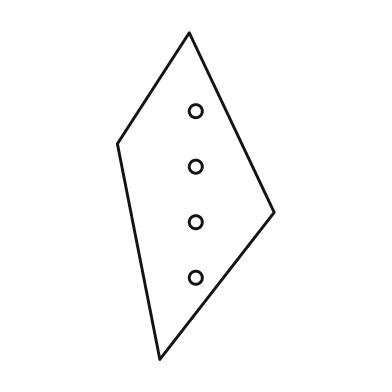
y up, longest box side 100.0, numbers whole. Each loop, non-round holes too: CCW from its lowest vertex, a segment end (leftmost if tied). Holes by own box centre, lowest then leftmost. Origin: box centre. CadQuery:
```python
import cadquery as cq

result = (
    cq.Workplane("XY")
    .moveTo(-11.0, -50.0)
    .lineTo(24.0, -5.0)
    .lineTo(-2.0, 50.0)
    .lineTo(-24.0, 16.0)
    .close()
    .moveTo(0.0, -25.0)
    .circle(2.0)
    .moveTo(0.0, -8.0)
    .circle(2.0)
    .moveTo(0.0, 9.0)
    .circle(2.0)
    .moveTo(0.0, 26.0)
    .circle(2.0)
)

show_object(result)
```